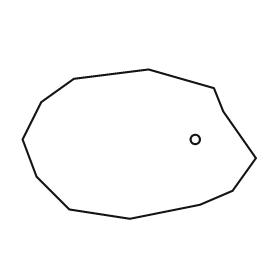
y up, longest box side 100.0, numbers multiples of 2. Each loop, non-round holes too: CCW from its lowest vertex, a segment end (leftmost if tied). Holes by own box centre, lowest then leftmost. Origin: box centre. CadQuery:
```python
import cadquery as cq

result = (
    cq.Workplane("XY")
    .moveTo(-4.0, -32.0)
    .lineTo(26.0, -26.0)
    .lineTo(40.0, -20.0)
    .lineTo(50.0, -6.0)
    .lineTo(36.0, 14.0)
    .lineTo(32.0, 24.0)
    .lineTo(4.0, 32.0)
    .lineTo(-28.0, 28.0)
    .lineTo(-42.0, 18.0)
    .lineTo(-50.0, 2.0)
    .lineTo(-44.0, -14.0)
    .lineTo(-30.0, -28.0)
    .close()
    .moveTo(24.0, 2.0)
    .circle(2.0)
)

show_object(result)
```